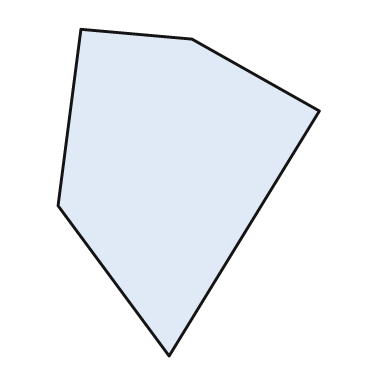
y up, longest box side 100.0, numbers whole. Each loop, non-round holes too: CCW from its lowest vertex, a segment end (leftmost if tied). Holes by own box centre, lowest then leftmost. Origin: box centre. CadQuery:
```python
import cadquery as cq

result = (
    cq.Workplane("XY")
    .moveTo(-6.0, -50.0)
    .lineTo(40.0, 25.0)
    .lineTo(1.0, 47.0)
    .lineTo(-33.0, 50.0)
    .lineTo(-40.0, -4.0)
    .close()
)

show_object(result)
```